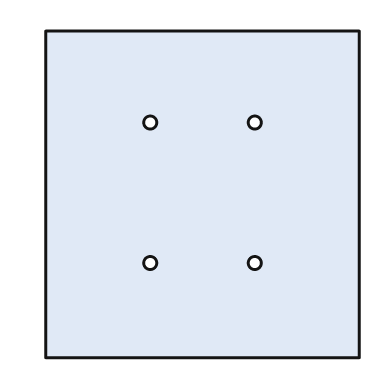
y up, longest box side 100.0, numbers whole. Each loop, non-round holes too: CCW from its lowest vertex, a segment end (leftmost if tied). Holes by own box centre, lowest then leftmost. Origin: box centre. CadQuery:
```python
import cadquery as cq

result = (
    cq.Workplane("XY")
    .moveTo(-48.0, -50.0)
    .lineTo(48.0, -50.0)
    .lineTo(48.0, 50.0)
    .lineTo(-48.0, 50.0)
    .close()
    .moveTo(-16.0, -21.0)
    .circle(2.0)
    .moveTo(16.0, -21.0)
    .circle(2.0)
    .moveTo(-16.0, 22.0)
    .circle(2.0)
    .moveTo(16.0, 22.0)
    .circle(2.0)
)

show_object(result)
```